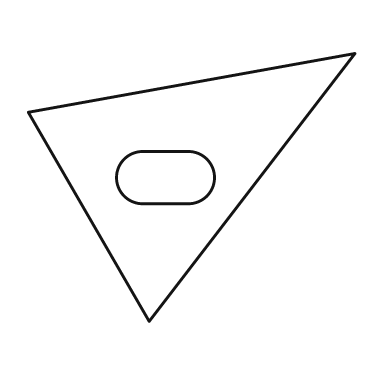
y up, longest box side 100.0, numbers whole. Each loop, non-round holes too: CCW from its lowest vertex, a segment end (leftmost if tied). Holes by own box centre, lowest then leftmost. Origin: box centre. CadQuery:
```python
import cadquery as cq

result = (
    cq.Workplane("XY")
    .moveTo(-13.0, -41.0)
    .lineTo(50.0, 41.0)
    .lineTo(-50.0, 23.0)
    .close()
    .moveTo(-15.0, -5.0)
    .lineTo(-1.0, -5.0)
    .threePointArc((7.0, 3.0), (-1.0, 11.0))
    .lineTo(-15.0, 11.0)
    .threePointArc((-23.0, 3.0), (-15.0, -5.0))
    .close()
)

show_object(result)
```